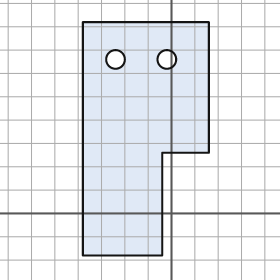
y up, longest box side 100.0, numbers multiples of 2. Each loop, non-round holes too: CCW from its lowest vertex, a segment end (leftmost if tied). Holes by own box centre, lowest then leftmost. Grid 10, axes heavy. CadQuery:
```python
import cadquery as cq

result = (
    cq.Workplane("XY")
    .moveTo(-38.0, -18.0)
    .lineTo(-4.0, -18.0)
    .lineTo(-4.0, 26.0)
    .lineTo(16.0, 26.0)
    .lineTo(16.0, 82.0)
    .lineTo(-38.0, 82.0)
    .close()
    .moveTo(-24.0, 66.0)
    .circle(4.0)
    .moveTo(-2.0, 66.0)
    .circle(4.0)
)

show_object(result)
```